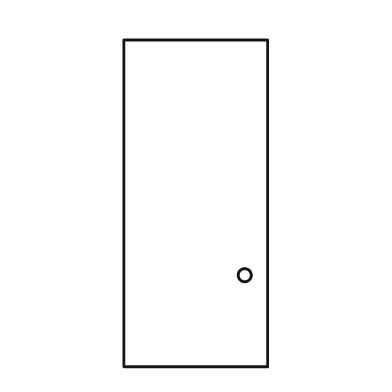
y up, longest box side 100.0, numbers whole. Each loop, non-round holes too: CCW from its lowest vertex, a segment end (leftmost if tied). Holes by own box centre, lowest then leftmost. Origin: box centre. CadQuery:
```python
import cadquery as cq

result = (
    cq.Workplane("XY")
    .moveTo(-22.0, -50.0)
    .lineTo(22.0, -50.0)
    .lineTo(22.0, 50.0)
    .lineTo(-22.0, 50.0)
    .close()
    .moveTo(15.0, -22.0)
    .circle(2.0)
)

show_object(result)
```